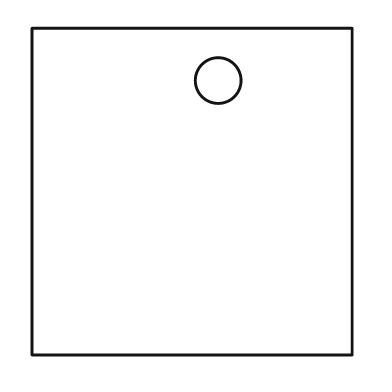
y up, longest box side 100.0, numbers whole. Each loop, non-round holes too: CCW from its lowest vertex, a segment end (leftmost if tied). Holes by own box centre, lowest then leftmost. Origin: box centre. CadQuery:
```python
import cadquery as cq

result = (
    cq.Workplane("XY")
    .moveTo(-49.0, -50.0)
    .lineTo(49.0, -50.0)
    .lineTo(49.0, 50.0)
    .lineTo(-49.0, 50.0)
    .close()
    .moveTo(8.0, 34.0)
    .circle(7.0)
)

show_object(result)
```